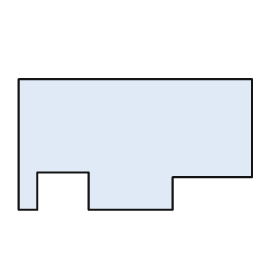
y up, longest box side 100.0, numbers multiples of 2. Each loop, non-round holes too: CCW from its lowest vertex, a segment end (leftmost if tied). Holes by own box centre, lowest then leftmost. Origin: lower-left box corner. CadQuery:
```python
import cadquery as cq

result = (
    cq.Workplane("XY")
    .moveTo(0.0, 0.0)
    .lineTo(8.0, 0.0)
    .lineTo(8.0, 16.0)
    .lineTo(30.0, 16.0)
    .lineTo(30.0, 0.0)
    .lineTo(66.0, 0.0)
    .lineTo(66.0, 14.0)
    .lineTo(100.0, 14.0)
    .lineTo(100.0, 56.0)
    .lineTo(0.0, 56.0)
    .close()
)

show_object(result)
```